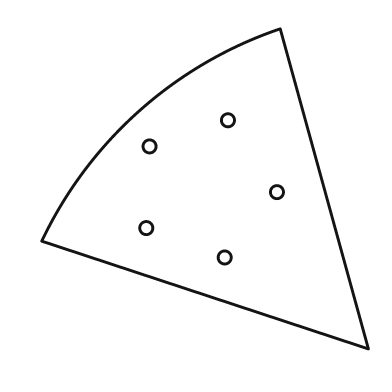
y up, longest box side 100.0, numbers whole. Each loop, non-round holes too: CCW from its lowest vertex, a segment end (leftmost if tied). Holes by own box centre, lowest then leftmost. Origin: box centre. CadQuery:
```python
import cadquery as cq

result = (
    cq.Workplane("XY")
    .moveTo(50.0, -49.0)
    .lineTo(23.0, 49.0)
    .threePointArc((-20.0, 24.0), (-50.0, -16.0))
    .close()
    .moveTo(6.0, -21.0)
    .circle(2.0)
    .moveTo(-18.0, -12.0)
    .circle(2.0)
    .moveTo(22.0, -1.0)
    .circle(2.0)
    .moveTo(-17.0, 13.0)
    .circle(2.0)
    .moveTo(7.0, 21.0)
    .circle(2.0)
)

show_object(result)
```